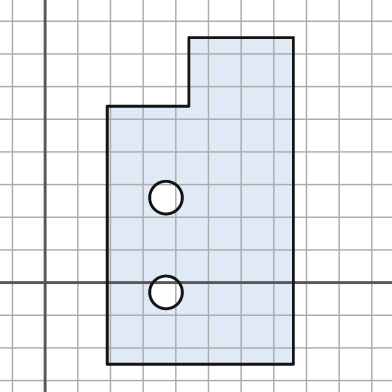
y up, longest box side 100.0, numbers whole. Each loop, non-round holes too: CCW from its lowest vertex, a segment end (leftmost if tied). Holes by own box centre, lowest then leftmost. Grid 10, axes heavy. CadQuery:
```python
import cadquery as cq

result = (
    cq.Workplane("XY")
    .moveTo(19.0, -25.0)
    .lineTo(76.0, -25.0)
    .lineTo(76.0, 75.0)
    .lineTo(44.0, 75.0)
    .lineTo(44.0, 54.0)
    .lineTo(19.0, 54.0)
    .close()
    .moveTo(37.0, -3.0)
    .circle(5.0)
    .moveTo(37.0, 26.0)
    .circle(5.0)
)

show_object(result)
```